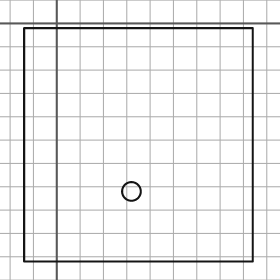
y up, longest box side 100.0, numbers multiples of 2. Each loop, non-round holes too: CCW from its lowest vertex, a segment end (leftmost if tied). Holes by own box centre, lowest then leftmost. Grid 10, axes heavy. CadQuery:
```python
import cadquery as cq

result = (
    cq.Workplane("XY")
    .moveTo(-14.0, -102.0)
    .lineTo(84.0, -102.0)
    .lineTo(84.0, -2.0)
    .lineTo(-14.0, -2.0)
    .close()
    .moveTo(32.0, -72.0)
    .circle(4.0)
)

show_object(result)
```